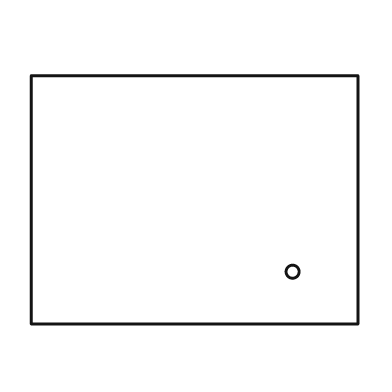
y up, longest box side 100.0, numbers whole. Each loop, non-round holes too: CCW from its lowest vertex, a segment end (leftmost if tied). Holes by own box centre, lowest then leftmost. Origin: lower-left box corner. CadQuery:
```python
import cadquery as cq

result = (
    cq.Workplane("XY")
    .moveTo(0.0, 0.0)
    .lineTo(100.0, 0.0)
    .lineTo(100.0, 76.0)
    .lineTo(0.0, 76.0)
    .close()
    .moveTo(80.0, 16.0)
    .circle(2.0)
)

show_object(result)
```